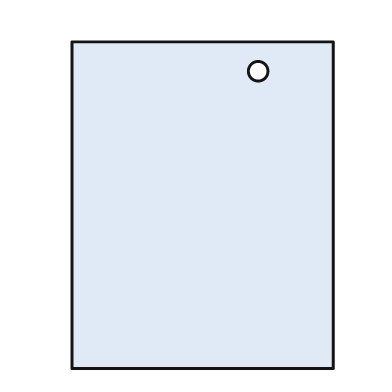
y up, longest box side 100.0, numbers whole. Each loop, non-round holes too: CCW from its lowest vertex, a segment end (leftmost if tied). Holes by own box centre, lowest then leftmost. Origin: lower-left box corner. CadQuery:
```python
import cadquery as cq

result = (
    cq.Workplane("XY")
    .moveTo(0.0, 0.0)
    .lineTo(80.0, 0.0)
    .lineTo(80.0, 100.0)
    .lineTo(0.0, 100.0)
    .close()
    .moveTo(57.0, 91.0)
    .circle(3.0)
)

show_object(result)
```